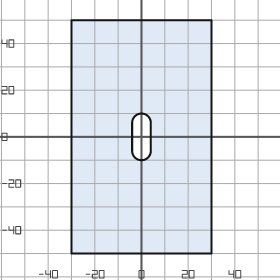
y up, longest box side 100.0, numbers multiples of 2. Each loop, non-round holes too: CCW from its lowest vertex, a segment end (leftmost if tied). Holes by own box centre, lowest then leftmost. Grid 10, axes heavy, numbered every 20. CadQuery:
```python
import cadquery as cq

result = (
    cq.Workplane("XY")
    .moveTo(-30.0, -50.0)
    .lineTo(30.0, -50.0)
    .lineTo(30.0, 50.0)
    .lineTo(-30.0, 50.0)
    .close()
    .moveTo(-4.0, -6.0)
    .threePointArc((0.0, -10.0), (4.0, -6.0))
    .lineTo(4.0, 6.0)
    .threePointArc((0.0, 10.0), (-4.0, 6.0))
    .close()
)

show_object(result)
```